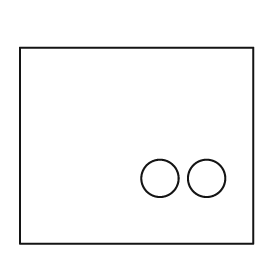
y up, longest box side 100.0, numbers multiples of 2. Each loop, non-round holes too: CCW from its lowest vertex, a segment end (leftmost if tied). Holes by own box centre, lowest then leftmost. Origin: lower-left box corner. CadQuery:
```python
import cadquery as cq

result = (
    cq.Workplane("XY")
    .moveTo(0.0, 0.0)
    .lineTo(100.0, 0.0)
    .lineTo(100.0, 84.0)
    .lineTo(0.0, 84.0)
    .close()
    .moveTo(60.0, 28.0)
    .circle(8.0)
    .moveTo(80.0, 28.0)
    .circle(8.0)
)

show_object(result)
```